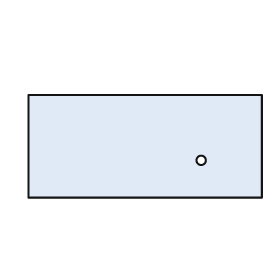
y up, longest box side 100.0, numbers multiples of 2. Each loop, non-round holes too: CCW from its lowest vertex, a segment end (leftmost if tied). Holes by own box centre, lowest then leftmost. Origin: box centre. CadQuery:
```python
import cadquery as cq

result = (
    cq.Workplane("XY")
    .moveTo(-50.0, -22.0)
    .lineTo(50.0, -22.0)
    .lineTo(50.0, 22.0)
    .lineTo(-50.0, 22.0)
    .close()
    .moveTo(24.0, -6.0)
    .circle(2.0)
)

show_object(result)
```